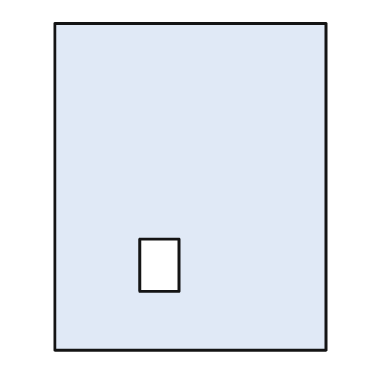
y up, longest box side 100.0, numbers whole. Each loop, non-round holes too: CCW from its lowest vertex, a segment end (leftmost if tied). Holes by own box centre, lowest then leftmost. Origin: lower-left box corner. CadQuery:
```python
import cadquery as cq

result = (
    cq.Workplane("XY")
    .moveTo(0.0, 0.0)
    .lineTo(83.0, 0.0)
    .lineTo(83.0, 100.0)
    .lineTo(0.0, 100.0)
    .close()
    .moveTo(26.0, 18.0)
    .lineTo(38.0, 18.0)
    .lineTo(38.0, 34.0)
    .lineTo(26.0, 34.0)
    .close()
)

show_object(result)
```